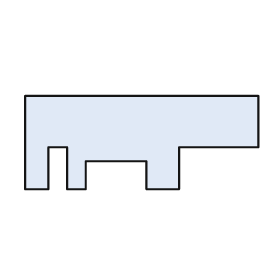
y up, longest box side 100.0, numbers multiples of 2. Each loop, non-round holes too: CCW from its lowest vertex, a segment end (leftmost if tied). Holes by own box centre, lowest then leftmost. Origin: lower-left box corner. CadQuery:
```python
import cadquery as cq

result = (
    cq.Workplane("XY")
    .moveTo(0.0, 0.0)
    .lineTo(10.0, 0.0)
    .lineTo(10.0, 18.0)
    .lineTo(18.0, 18.0)
    .lineTo(18.0, 0.0)
    .lineTo(26.0, 0.0)
    .lineTo(26.0, 12.0)
    .lineTo(52.0, 12.0)
    .lineTo(52.0, 0.0)
    .lineTo(66.0, 0.0)
    .lineTo(66.0, 18.0)
    .lineTo(100.0, 18.0)
    .lineTo(100.0, 40.0)
    .lineTo(0.0, 40.0)
    .close()
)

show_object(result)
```